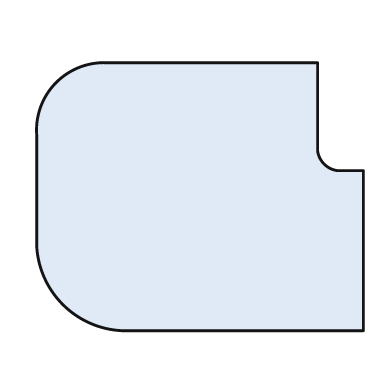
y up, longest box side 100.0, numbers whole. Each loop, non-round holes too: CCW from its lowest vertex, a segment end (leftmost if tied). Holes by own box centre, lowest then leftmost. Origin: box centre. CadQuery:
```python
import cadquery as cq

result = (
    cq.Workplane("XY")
    .moveTo(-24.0, -41.0)
    .lineTo(50.0, -41.0)
    .lineTo(50.0, 8.0)
    .lineTo(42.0, 8.0)
    .threePointArc((38.0, 10.0), (36.0, 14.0))
    .lineTo(36.0, 41.0)
    .lineTo(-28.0, 41.0)
    .threePointArc((-44.0, 35.0), (-50.0, 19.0))
    .lineTo(-50.0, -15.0)
    .threePointArc((-42.0, -33.0), (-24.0, -41.0))
    .close()
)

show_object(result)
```